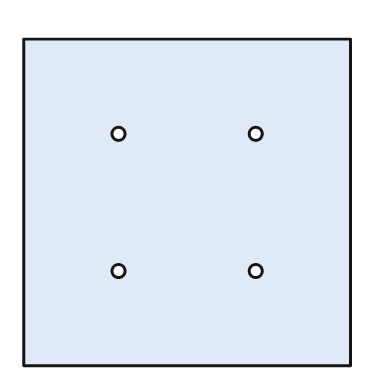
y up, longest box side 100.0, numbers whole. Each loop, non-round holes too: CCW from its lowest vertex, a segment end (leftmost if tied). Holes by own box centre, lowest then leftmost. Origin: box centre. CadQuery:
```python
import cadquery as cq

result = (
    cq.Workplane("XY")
    .moveTo(-50.0, -50.0)
    .lineTo(50.0, -50.0)
    .lineTo(50.0, 50.0)
    .lineTo(-50.0, 50.0)
    .close()
    .moveTo(-21.0, -21.0)
    .circle(2.0)
    .moveTo(21.0, -21.0)
    .circle(2.0)
    .moveTo(-21.0, 21.0)
    .circle(2.0)
    .moveTo(21.0, 21.0)
    .circle(2.0)
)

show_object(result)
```